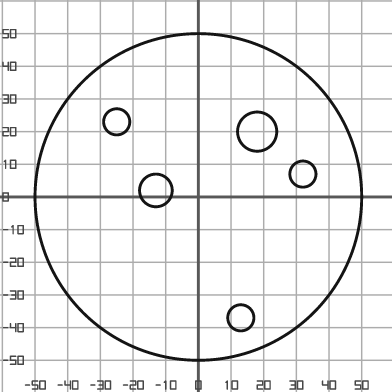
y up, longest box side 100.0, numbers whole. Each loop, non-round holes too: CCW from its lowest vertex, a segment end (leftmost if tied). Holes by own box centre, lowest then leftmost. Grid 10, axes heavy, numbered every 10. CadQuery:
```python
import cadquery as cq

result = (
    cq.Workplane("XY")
    .moveTo(0.0, 0.0)
    .circle(50.0)
    .moveTo(13.0, -37.0)
    .circle(4.0)
    .moveTo(-13.0, 2.0)
    .circle(5.0)
    .moveTo(32.0, 7.0)
    .circle(4.0)
    .moveTo(18.0, 20.0)
    .circle(6.0)
    .moveTo(-25.0, 23.0)
    .circle(4.0)
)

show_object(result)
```